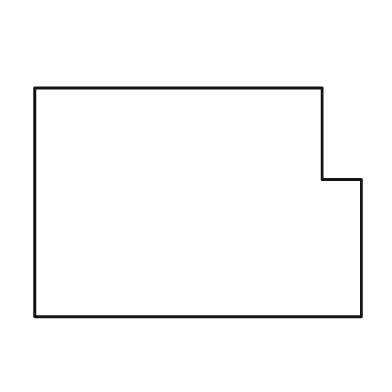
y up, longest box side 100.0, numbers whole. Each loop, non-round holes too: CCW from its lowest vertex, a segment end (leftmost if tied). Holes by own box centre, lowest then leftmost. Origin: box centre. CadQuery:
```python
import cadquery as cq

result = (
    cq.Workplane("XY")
    .moveTo(-50.0, -35.0)
    .lineTo(50.0, -35.0)
    .lineTo(50.0, 7.0)
    .lineTo(38.0, 7.0)
    .lineTo(38.0, 35.0)
    .lineTo(-50.0, 35.0)
    .close()
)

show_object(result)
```